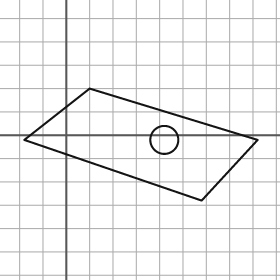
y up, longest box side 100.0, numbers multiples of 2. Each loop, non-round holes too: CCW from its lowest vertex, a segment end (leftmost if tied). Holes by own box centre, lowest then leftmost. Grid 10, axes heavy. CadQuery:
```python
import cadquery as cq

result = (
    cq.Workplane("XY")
    .moveTo(58.0, -28.0)
    .lineTo(82.0, -2.0)
    .lineTo(10.0, 20.0)
    .lineTo(-18.0, -2.0)
    .close()
    .moveTo(42.0, -2.0)
    .circle(6.0)
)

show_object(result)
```